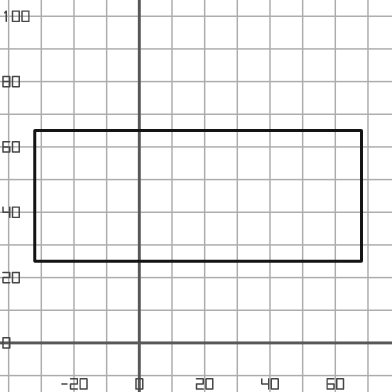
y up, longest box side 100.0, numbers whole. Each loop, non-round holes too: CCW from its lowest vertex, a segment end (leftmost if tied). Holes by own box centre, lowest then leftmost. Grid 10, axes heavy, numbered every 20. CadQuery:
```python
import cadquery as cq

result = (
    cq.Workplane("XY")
    .moveTo(-32.0, 25.0)
    .lineTo(68.0, 25.0)
    .lineTo(68.0, 65.0)
    .lineTo(-32.0, 65.0)
    .close()
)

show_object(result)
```